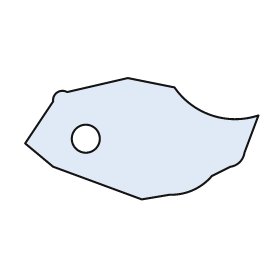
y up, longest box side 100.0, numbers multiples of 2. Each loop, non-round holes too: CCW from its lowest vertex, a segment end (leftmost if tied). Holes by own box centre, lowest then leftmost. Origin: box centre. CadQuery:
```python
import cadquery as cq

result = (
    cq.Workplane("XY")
    .moveTo(0.0, -26.0)
    .lineTo(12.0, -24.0)
    .threePointArc((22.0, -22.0), (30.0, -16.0))
    .lineTo(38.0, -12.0)
    .threePointArc((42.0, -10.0), (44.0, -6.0))
    .lineTo(50.0, 10.0)
    .threePointArc((30.0, 10.0), (14.0, 22.0))
    .lineTo(-6.0, 26.0)
    .lineTo(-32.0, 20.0)
    .threePointArc((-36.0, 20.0), (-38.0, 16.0))
    .lineTo(-50.0, -2.0)
    .lineTo(-38.0, -12.0)
    .close()
    .moveTo(-24.0, 0.0)
    .circle(6.0)
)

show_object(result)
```